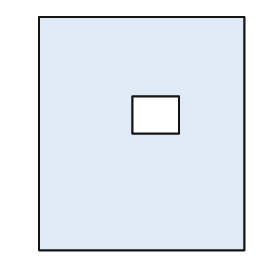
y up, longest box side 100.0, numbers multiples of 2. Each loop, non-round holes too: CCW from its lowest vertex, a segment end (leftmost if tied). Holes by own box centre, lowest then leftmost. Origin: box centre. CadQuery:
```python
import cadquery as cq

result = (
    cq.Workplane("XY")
    .moveTo(-44.0, -50.0)
    .lineTo(44.0, -50.0)
    .lineTo(44.0, 50.0)
    .lineTo(-44.0, 50.0)
    .close()
    .moveTo(-4.0, 0.0)
    .lineTo(16.0, 0.0)
    .lineTo(16.0, 16.0)
    .lineTo(-4.0, 16.0)
    .close()
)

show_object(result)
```